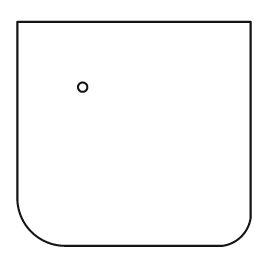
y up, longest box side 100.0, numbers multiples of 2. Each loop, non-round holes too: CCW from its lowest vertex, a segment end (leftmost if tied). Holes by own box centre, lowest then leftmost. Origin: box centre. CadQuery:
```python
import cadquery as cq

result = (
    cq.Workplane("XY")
    .moveTo(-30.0, -48.0)
    .lineTo(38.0, -48.0)
    .threePointArc((46.0, -44.0), (50.0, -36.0))
    .lineTo(50.0, 48.0)
    .lineTo(-50.0, 48.0)
    .lineTo(-50.0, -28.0)
    .threePointArc((-44.0, -42.0), (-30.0, -48.0))
    .close()
    .moveTo(-22.0, 20.0)
    .circle(2.0)
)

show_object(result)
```